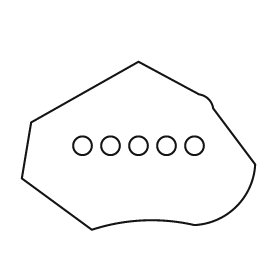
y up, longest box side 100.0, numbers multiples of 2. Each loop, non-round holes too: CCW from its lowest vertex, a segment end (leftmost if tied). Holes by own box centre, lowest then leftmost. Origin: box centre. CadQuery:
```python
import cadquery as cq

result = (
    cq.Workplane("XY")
    .moveTo(-20.0, -36.0)
    .threePointArc((2.0, -32.0), (24.0, -34.0))
    .threePointArc((42.0, -26.0), (50.0, -8.0))
    .lineTo(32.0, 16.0)
    .threePointArc((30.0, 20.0), (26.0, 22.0))
    .lineTo(0.0, 36.0)
    .lineTo(-46.0, 10.0)
    .lineTo(-50.0, -14.0)
    .close()
    .moveTo(-24.0, 0.0)
    .circle(4.0)
    .moveTo(-12.0, 0.0)
    .circle(4.0)
    .moveTo(0.0, 0.0)
    .circle(4.0)
    .moveTo(12.0, 0.0)
    .circle(4.0)
    .moveTo(24.0, 0.0)
    .circle(4.0)
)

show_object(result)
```